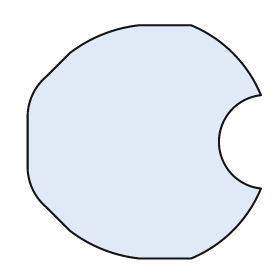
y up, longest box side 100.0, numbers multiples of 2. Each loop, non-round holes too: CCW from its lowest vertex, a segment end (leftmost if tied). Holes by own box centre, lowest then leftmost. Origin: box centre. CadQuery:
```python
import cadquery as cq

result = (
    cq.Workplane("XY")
    .moveTo(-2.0, -50.0)
    .lineTo(20.0, -50.0)
    .threePointArc((38.0, -38.0), (50.0, -20.0))
    .threePointArc((32.0, 0.0), (50.0, 20.0))
    .threePointArc((38.0, 38.0), (20.0, 50.0))
    .lineTo(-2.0, 50.0)
    .threePointArc((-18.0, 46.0), (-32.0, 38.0))
    .lineTo(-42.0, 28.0)
    .threePointArc((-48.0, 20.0), (-50.0, 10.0))
    .lineTo(-50.0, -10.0)
    .threePointArc((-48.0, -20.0), (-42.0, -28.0))
    .lineTo(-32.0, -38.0)
    .threePointArc((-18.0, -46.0), (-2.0, -50.0))
    .close()
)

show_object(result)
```